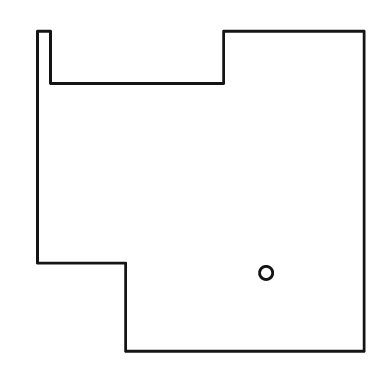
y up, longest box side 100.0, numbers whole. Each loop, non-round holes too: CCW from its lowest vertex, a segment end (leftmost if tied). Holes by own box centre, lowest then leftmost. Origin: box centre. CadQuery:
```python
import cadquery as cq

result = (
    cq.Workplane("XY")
    .moveTo(-23.0, -49.0)
    .lineTo(50.0, -49.0)
    .lineTo(50.0, 49.0)
    .lineTo(7.0, 49.0)
    .lineTo(7.0, 33.0)
    .lineTo(-46.0, 33.0)
    .lineTo(-46.0, 49.0)
    .lineTo(-50.0, 49.0)
    .lineTo(-50.0, -22.0)
    .lineTo(-23.0, -22.0)
    .close()
    .moveTo(20.0, -25.0)
    .circle(2.0)
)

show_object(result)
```